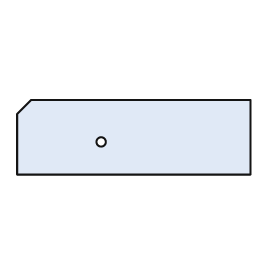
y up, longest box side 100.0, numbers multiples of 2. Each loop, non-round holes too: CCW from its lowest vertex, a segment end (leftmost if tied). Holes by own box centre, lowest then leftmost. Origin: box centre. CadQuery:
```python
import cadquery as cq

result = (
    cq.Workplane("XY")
    .moveTo(-50.0, -16.0)
    .lineTo(50.0, -16.0)
    .lineTo(50.0, 16.0)
    .lineTo(-44.0, 16.0)
    .lineTo(-50.0, 10.0)
    .close()
    .moveTo(-14.0, -2.0)
    .circle(2.0)
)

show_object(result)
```